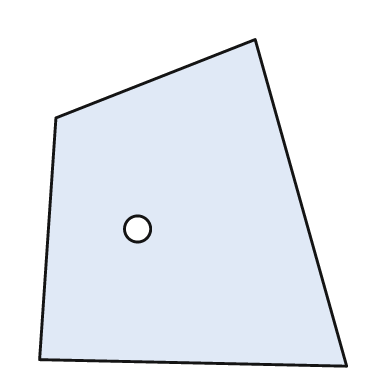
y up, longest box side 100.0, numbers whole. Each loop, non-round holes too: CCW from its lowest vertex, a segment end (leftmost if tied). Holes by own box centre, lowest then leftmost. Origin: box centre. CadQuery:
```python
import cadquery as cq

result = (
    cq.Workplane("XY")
    .moveTo(47.0, -50.0)
    .lineTo(19.0, 50.0)
    .lineTo(-42.0, 26.0)
    .lineTo(-47.0, -48.0)
    .close()
    .moveTo(-17.0, -8.0)
    .circle(4.0)
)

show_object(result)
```